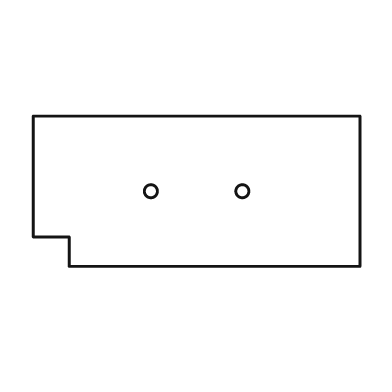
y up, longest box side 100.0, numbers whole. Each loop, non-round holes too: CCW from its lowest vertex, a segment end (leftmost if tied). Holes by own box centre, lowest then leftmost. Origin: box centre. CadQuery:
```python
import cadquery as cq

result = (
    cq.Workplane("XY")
    .moveTo(-39.0, -23.0)
    .lineTo(50.0, -23.0)
    .lineTo(50.0, 23.0)
    .lineTo(-50.0, 23.0)
    .lineTo(-50.0, -14.0)
    .lineTo(-39.0, -14.0)
    .close()
    .moveTo(-14.0, 0.0)
    .circle(2.0)
    .moveTo(14.0, 0.0)
    .circle(2.0)
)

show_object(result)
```